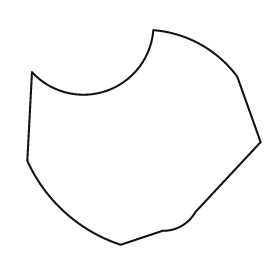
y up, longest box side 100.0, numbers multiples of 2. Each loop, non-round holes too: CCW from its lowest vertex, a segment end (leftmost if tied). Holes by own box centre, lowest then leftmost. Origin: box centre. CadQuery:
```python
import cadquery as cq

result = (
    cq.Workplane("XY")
    .moveTo(-10.0, -46.0)
    .lineTo(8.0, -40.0)
    .threePointArc((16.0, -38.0), (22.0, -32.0))
    .lineTo(50.0, -2.0)
    .lineTo(40.0, 26.0)
    .threePointArc((24.0, 40.0), (4.0, 46.0))
    .threePointArc((-16.0, 20.0), (-48.0, 28.0))
    .lineTo(-50.0, -10.0)
    .threePointArc((-34.0, -32.0), (-10.0, -46.0))
    .close()
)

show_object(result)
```